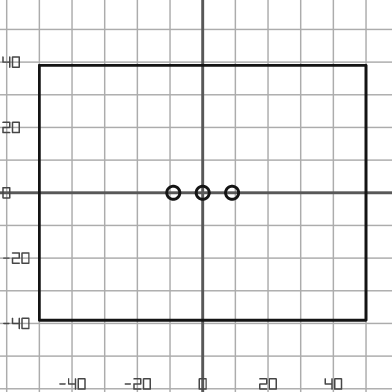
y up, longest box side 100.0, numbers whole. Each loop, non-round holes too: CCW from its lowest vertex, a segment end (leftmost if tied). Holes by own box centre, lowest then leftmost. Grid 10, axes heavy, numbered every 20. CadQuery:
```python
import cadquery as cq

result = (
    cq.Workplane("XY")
    .moveTo(-50.0, -39.0)
    .lineTo(50.0, -39.0)
    .lineTo(50.0, 39.0)
    .lineTo(-50.0, 39.0)
    .close()
    .moveTo(-9.0, 0.0)
    .circle(2.0)
    .moveTo(0.0, 0.0)
    .circle(2.0)
    .moveTo(9.0, 0.0)
    .circle(2.0)
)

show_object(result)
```